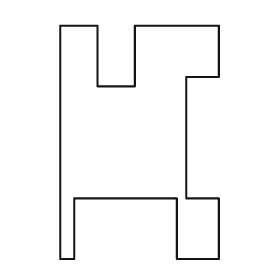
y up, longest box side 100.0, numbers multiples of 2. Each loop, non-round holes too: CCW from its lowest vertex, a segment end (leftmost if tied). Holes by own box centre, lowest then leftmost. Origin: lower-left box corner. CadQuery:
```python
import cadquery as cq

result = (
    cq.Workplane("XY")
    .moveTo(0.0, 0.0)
    .lineTo(6.0, 0.0)
    .lineTo(6.0, 26.0)
    .lineTo(50.0, 26.0)
    .lineTo(50.0, 0.0)
    .lineTo(68.0, 0.0)
    .lineTo(68.0, 26.0)
    .lineTo(54.0, 26.0)
    .lineTo(54.0, 78.0)
    .lineTo(68.0, 78.0)
    .lineTo(68.0, 100.0)
    .lineTo(32.0, 100.0)
    .lineTo(32.0, 74.0)
    .lineTo(16.0, 74.0)
    .lineTo(16.0, 100.0)
    .lineTo(0.0, 100.0)
    .close()
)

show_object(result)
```